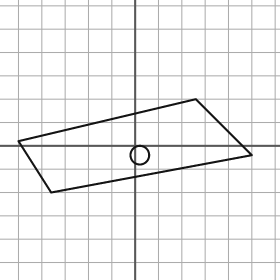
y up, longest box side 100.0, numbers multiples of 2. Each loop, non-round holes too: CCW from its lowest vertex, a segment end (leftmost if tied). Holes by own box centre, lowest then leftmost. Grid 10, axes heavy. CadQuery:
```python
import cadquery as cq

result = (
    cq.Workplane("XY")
    .moveTo(-36.0, -20.0)
    .lineTo(50.0, -4.0)
    .lineTo(26.0, 20.0)
    .lineTo(-50.0, 2.0)
    .close()
    .moveTo(2.0, -4.0)
    .circle(4.0)
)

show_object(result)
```